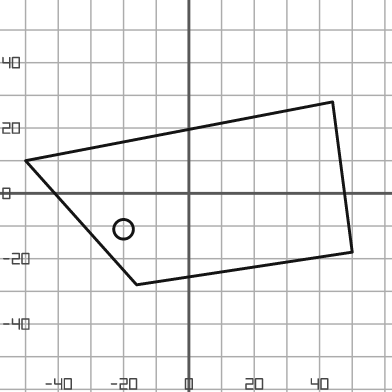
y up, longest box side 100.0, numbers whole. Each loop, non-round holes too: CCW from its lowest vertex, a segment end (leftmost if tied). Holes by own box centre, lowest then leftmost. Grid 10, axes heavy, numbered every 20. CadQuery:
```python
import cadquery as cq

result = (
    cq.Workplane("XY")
    .moveTo(-16.0, -28.0)
    .lineTo(50.0, -18.0)
    .lineTo(44.0, 28.0)
    .lineTo(-50.0, 10.0)
    .close()
    .moveTo(-20.0, -11.0)
    .circle(3.0)
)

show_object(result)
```